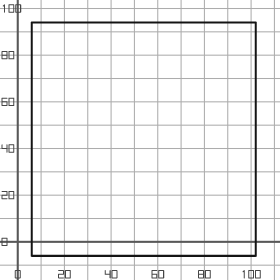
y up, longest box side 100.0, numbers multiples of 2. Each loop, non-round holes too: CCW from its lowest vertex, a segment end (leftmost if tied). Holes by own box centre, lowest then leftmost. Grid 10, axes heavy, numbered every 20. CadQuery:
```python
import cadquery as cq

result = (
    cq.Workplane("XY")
    .moveTo(6.0, -6.0)
    .lineTo(102.0, -6.0)
    .lineTo(102.0, 94.0)
    .lineTo(6.0, 94.0)
    .close()
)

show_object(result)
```